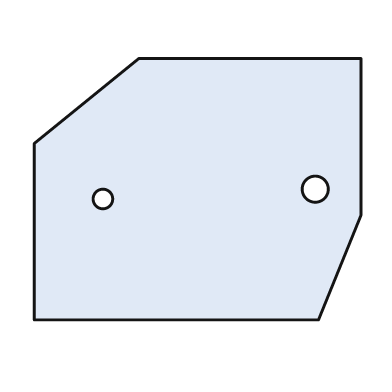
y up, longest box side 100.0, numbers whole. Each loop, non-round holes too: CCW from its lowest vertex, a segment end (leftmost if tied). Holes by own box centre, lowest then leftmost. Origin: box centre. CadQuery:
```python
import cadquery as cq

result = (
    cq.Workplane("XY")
    .moveTo(-50.0, -40.0)
    .lineTo(37.0, -40.0)
    .lineTo(50.0, -8.0)
    .lineTo(50.0, 40.0)
    .lineTo(-18.0, 40.0)
    .lineTo(-50.0, 14.0)
    .close()
    .moveTo(-29.0, -3.0)
    .circle(3.0)
    .moveTo(36.0, 0.0)
    .circle(4.0)
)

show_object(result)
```